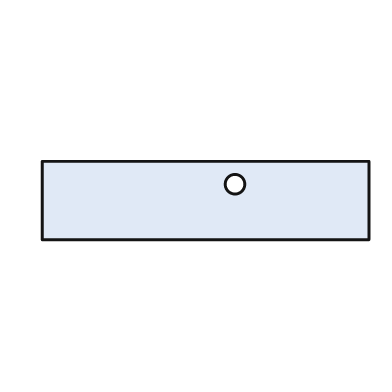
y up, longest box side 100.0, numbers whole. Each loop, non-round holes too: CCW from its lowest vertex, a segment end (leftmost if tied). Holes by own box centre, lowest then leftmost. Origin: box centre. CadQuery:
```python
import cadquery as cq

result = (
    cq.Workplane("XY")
    .moveTo(-50.0, -12.0)
    .lineTo(50.0, -12.0)
    .lineTo(50.0, 12.0)
    .lineTo(-50.0, 12.0)
    .close()
    .moveTo(9.0, 5.0)
    .circle(3.0)
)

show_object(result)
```